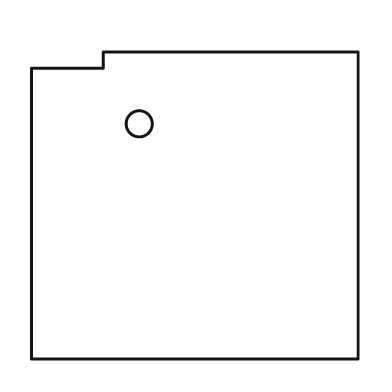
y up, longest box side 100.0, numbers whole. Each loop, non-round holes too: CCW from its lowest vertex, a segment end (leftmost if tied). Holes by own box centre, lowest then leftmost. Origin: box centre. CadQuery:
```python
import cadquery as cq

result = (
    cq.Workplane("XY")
    .moveTo(-50.0, -47.0)
    .lineTo(50.0, -47.0)
    .lineTo(50.0, 47.0)
    .lineTo(-28.0, 47.0)
    .lineTo(-28.0, 42.0)
    .lineTo(-50.0, 42.0)
    .close()
    .moveTo(-17.0, 25.0)
    .circle(4.0)
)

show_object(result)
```